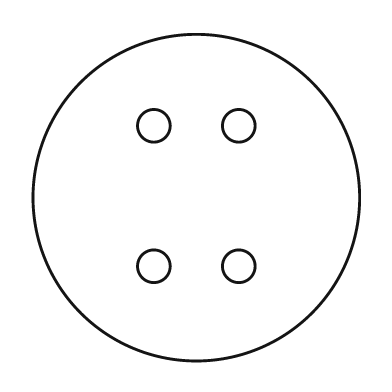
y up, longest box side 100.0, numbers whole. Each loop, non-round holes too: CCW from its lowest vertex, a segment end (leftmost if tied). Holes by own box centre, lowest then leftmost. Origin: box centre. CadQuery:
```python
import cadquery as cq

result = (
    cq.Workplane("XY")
    .moveTo(0.0, 0.0)
    .circle(50.0)
    .moveTo(-13.0, -21.0)
    .circle(5.0)
    .moveTo(13.0, -21.0)
    .circle(5.0)
    .moveTo(-13.0, 22.0)
    .circle(5.0)
    .moveTo(13.0, 22.0)
    .circle(5.0)
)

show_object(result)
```